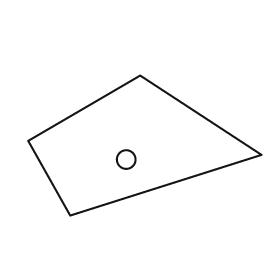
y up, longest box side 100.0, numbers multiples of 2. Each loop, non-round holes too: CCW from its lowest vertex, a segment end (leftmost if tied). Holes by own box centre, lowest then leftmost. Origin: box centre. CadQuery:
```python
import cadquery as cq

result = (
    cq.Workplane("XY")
    .moveTo(-32.0, -30.0)
    .lineTo(50.0, -4.0)
    .lineTo(-2.0, 30.0)
    .lineTo(-50.0, 2.0)
    .close()
    .moveTo(-8.0, -6.0)
    .circle(4.0)
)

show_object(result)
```